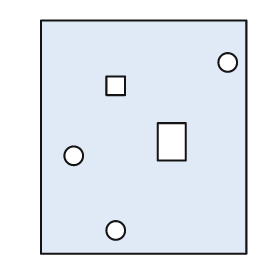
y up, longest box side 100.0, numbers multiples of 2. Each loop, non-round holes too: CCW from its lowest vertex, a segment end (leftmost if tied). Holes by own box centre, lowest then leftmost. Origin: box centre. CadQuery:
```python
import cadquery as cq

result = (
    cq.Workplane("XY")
    .moveTo(-44.0, -50.0)
    .lineTo(44.0, -50.0)
    .lineTo(44.0, 50.0)
    .lineTo(-44.0, 50.0)
    .close()
    .moveTo(-12.0, -40.0)
    .circle(4.0)
    .moveTo(-30.0, -8.0)
    .circle(4.0)
    .moveTo(6.0, -10.0)
    .lineTo(18.0, -10.0)
    .lineTo(18.0, 6.0)
    .lineTo(6.0, 6.0)
    .close()
    .moveTo(-16.0, 18.0)
    .lineTo(-8.0, 18.0)
    .lineTo(-8.0, 26.0)
    .lineTo(-16.0, 26.0)
    .close()
    .moveTo(36.0, 32.0)
    .circle(4.0)
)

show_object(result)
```